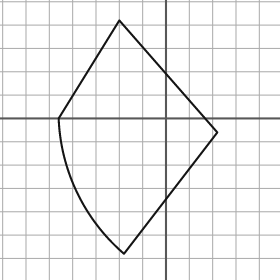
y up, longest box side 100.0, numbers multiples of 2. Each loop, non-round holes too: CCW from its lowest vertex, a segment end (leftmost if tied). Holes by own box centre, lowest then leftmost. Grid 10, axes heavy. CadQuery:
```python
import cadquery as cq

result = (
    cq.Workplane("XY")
    .moveTo(-18.0, -58.0)
    .lineTo(22.0, -6.0)
    .lineTo(-20.0, 42.0)
    .lineTo(-46.0, 0.0)
    .threePointArc((-38.0, -32.0), (-18.0, -58.0))
    .close()
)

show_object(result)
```